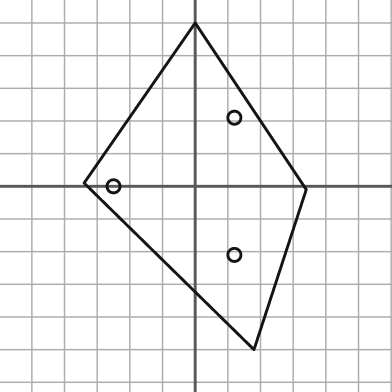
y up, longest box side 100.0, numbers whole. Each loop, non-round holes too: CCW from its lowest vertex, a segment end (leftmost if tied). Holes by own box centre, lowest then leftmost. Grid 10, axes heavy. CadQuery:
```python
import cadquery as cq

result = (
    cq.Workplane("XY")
    .moveTo(18.0, -50.0)
    .lineTo(34.0, -1.0)
    .lineTo(0.0, 50.0)
    .lineTo(-34.0, 1.0)
    .close()
    .moveTo(12.0, -21.0)
    .circle(2.0)
    .moveTo(-25.0, 0.0)
    .circle(2.0)
    .moveTo(12.0, 21.0)
    .circle(2.0)
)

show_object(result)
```